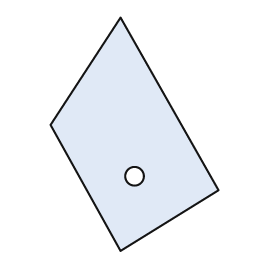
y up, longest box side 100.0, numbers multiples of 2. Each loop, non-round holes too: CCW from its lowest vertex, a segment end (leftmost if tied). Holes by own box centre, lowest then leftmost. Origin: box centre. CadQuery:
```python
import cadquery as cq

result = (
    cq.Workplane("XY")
    .moveTo(-6.0, -50.0)
    .lineTo(36.0, -24.0)
    .lineTo(-6.0, 50.0)
    .lineTo(-36.0, 4.0)
    .close()
    .moveTo(0.0, -18.0)
    .circle(4.0)
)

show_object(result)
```